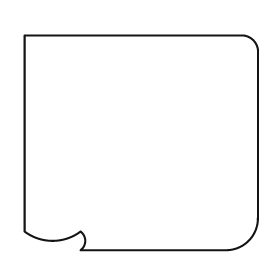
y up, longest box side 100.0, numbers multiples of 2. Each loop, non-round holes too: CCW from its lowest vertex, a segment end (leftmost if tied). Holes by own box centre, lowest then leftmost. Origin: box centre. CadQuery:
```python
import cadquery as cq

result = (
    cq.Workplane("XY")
    .moveTo(-26.0, -46.0)
    .lineTo(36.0, -46.0)
    .threePointArc((46.0, -42.0), (50.0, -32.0))
    .lineTo(50.0, 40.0)
    .threePointArc((48.0, 44.0), (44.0, 46.0))
    .lineTo(-50.0, 46.0)
    .lineTo(-50.0, -38.0)
    .threePointArc((-38.0, -42.0), (-26.0, -38.0))
    .threePointArc((-24.0, -42.0), (-26.0, -46.0))
    .close()
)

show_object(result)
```